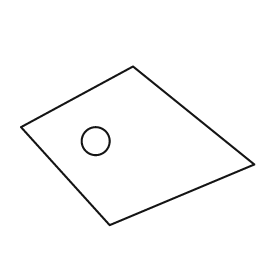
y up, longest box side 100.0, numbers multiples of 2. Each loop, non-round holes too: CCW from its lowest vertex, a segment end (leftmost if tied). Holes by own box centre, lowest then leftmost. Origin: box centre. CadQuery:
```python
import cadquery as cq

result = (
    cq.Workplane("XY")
    .moveTo(-12.0, -34.0)
    .lineTo(50.0, -8.0)
    .lineTo(-2.0, 34.0)
    .lineTo(-50.0, 8.0)
    .close()
    .moveTo(-18.0, 2.0)
    .circle(6.0)
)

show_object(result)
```